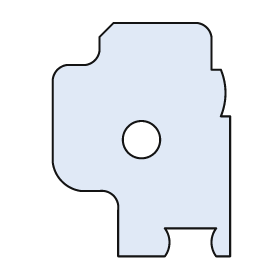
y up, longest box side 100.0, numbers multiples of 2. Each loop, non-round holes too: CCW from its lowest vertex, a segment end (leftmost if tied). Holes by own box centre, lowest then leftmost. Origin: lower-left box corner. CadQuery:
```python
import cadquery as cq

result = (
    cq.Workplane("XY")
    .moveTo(28.0, 0.0)
    .lineTo(48.0, 0.0)
    .threePointArc((50.0, 6.0), (48.0, 12.0))
    .lineTo(70.0, 12.0)
    .threePointArc((68.0, 6.0), (70.0, 0.0))
    .lineTo(76.0, 0.0)
    .lineTo(76.0, 60.0)
    .lineTo(72.0, 60.0)
    .threePointArc((74.0, 70.0), (72.0, 80.0))
    .lineTo(68.0, 80.0)
    .lineTo(68.0, 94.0)
    .threePointArc((66.0, 98.0), (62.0, 100.0))
    .lineTo(26.0, 100.0)
    .lineTo(20.0, 94.0)
    .lineTo(20.0, 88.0)
    .threePointArc((18.0, 84.0), (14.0, 82.0))
    .lineTo(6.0, 82.0)
    .threePointArc((2.0, 80.0), (0.0, 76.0))
    .lineTo(0.0, 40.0)
    .threePointArc((4.0, 32.0), (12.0, 28.0))
    .lineTo(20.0, 28.0)
    .threePointArc((26.0, 26.0), (28.0, 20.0))
    .close()
    .moveTo(38.0, 50.0)
    .circle(8.0)
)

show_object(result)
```